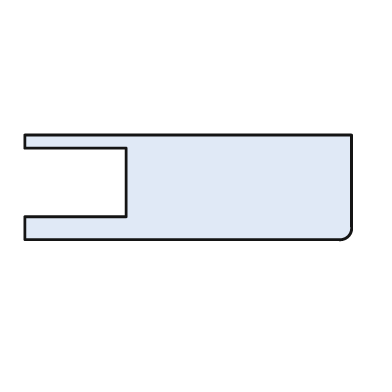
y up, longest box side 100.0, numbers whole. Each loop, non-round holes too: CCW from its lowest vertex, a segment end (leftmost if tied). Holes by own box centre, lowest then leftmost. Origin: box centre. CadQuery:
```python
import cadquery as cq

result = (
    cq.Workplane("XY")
    .moveTo(-50.0, -16.0)
    .lineTo(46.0, -16.0)
    .threePointArc((49.0, -15.0), (50.0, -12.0))
    .lineTo(50.0, 16.0)
    .lineTo(-50.0, 16.0)
    .lineTo(-50.0, 12.0)
    .lineTo(-19.0, 12.0)
    .lineTo(-19.0, -9.0)
    .lineTo(-50.0, -9.0)
    .close()
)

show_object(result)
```